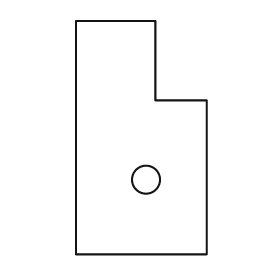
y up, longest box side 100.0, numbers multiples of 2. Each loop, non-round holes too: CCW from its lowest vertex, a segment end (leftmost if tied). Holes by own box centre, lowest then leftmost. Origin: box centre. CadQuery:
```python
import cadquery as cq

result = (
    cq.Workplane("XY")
    .moveTo(-28.0, -50.0)
    .lineTo(28.0, -50.0)
    .lineTo(28.0, 16.0)
    .lineTo(6.0, 16.0)
    .lineTo(6.0, 50.0)
    .lineTo(-28.0, 50.0)
    .close()
    .moveTo(2.0, -18.0)
    .circle(6.0)
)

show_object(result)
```